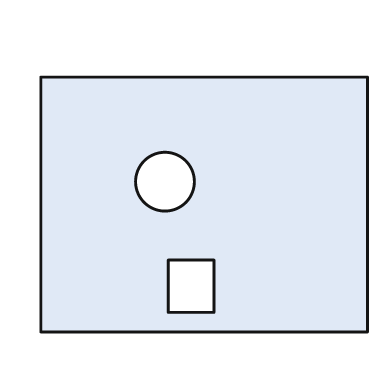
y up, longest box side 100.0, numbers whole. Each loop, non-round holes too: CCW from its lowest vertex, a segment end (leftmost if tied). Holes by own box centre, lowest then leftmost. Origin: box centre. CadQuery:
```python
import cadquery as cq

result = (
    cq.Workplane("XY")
    .moveTo(-50.0, -39.0)
    .lineTo(50.0, -39.0)
    .lineTo(50.0, 39.0)
    .lineTo(-50.0, 39.0)
    .close()
    .moveTo(-11.0, -33.0)
    .lineTo(3.0, -33.0)
    .lineTo(3.0, -17.0)
    .lineTo(-11.0, -17.0)
    .close()
    .moveTo(-12.0, 7.0)
    .circle(9.0)
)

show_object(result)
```